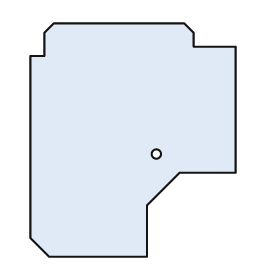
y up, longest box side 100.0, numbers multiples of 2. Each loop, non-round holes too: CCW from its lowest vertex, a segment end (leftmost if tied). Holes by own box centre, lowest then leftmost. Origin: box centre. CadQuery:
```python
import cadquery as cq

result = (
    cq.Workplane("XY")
    .moveTo(-36.0, -50.0)
    .lineTo(6.0, -50.0)
    .lineTo(6.0, -28.0)
    .lineTo(20.0, -14.0)
    .lineTo(44.0, -14.0)
    .lineTo(44.0, 40.0)
    .lineTo(26.0, 40.0)
    .lineTo(26.0, 46.0)
    .lineTo(22.0, 50.0)
    .lineTo(-34.0, 50.0)
    .lineTo(-38.0, 46.0)
    .lineTo(-38.0, 36.0)
    .lineTo(-44.0, 36.0)
    .lineTo(-44.0, -42.0)
    .close()
    .moveTo(10.0, -6.0)
    .circle(2.0)
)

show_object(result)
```